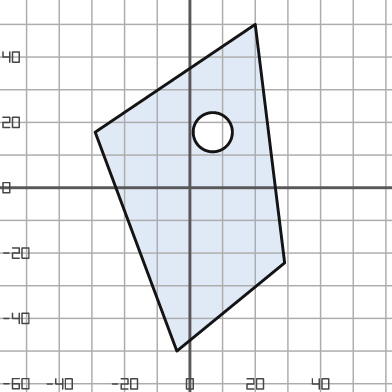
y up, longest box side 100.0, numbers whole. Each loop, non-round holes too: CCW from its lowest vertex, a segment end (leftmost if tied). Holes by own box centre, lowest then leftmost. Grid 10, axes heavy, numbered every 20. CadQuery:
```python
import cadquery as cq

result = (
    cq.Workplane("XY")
    .moveTo(-4.0, -50.0)
    .lineTo(29.0, -23.0)
    .lineTo(20.0, 50.0)
    .lineTo(-29.0, 17.0)
    .close()
    .moveTo(7.0, 17.0)
    .circle(6.0)
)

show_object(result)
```